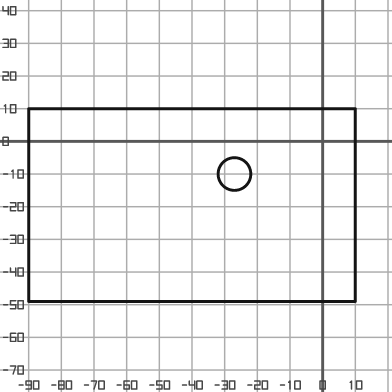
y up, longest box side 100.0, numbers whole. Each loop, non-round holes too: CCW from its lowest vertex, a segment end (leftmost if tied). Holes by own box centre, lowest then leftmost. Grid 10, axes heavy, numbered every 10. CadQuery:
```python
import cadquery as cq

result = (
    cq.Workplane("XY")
    .moveTo(-90.0, -49.0)
    .lineTo(10.0, -49.0)
    .lineTo(10.0, 10.0)
    .lineTo(-90.0, 10.0)
    .close()
    .moveTo(-27.0, -10.0)
    .circle(5.0)
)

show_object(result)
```